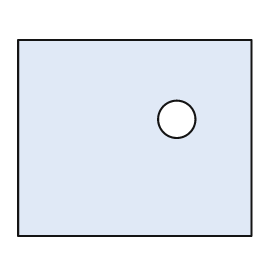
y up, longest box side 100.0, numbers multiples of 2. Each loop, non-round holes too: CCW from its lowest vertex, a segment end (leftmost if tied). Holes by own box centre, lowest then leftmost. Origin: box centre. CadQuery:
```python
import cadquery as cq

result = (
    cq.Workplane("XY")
    .moveTo(-50.0, -42.0)
    .lineTo(50.0, -42.0)
    .lineTo(50.0, 42.0)
    .lineTo(-50.0, 42.0)
    .close()
    .moveTo(18.0, 8.0)
    .circle(8.0)
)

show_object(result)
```